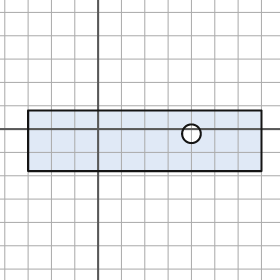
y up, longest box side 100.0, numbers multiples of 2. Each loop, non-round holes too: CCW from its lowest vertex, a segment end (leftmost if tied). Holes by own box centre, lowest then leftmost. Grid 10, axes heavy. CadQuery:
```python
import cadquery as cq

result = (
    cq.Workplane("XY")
    .moveTo(-30.0, -18.0)
    .lineTo(70.0, -18.0)
    .lineTo(70.0, 8.0)
    .lineTo(-30.0, 8.0)
    .close()
    .moveTo(40.0, -2.0)
    .circle(4.0)
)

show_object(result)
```